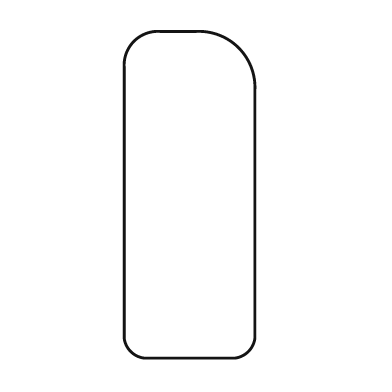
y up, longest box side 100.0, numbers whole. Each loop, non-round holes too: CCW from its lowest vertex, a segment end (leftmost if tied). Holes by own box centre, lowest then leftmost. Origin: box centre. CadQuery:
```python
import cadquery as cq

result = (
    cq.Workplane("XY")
    .moveTo(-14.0, -50.0)
    .lineTo(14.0, -50.0)
    .threePointArc((18.0, -48.0), (20.0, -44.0))
    .lineTo(20.0, 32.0)
    .threePointArc((15.0, 45.0), (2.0, 50.0))
    .lineTo(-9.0, 50.0)
    .threePointArc((-17.0, 47.0), (-20.0, 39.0))
    .lineTo(-20.0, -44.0)
    .threePointArc((-18.0, -48.0), (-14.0, -50.0))
    .close()
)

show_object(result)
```